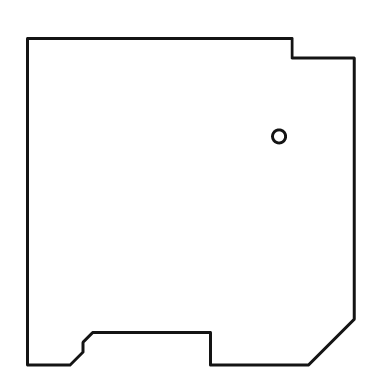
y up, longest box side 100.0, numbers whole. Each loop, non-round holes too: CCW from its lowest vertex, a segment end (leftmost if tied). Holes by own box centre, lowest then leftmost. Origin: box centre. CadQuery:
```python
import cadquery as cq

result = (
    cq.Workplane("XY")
    .moveTo(-50.0, -50.0)
    .lineTo(-37.0, -50.0)
    .lineTo(-33.0, -46.0)
    .lineTo(-33.0, -43.0)
    .lineTo(-30.0, -40.0)
    .lineTo(6.0, -40.0)
    .lineTo(6.0, -50.0)
    .lineTo(36.0, -50.0)
    .lineTo(50.0, -36.0)
    .lineTo(50.0, 44.0)
    .lineTo(31.0, 44.0)
    .lineTo(31.0, 50.0)
    .lineTo(-50.0, 50.0)
    .close()
    .moveTo(27.0, 20.0)
    .circle(2.0)
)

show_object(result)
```